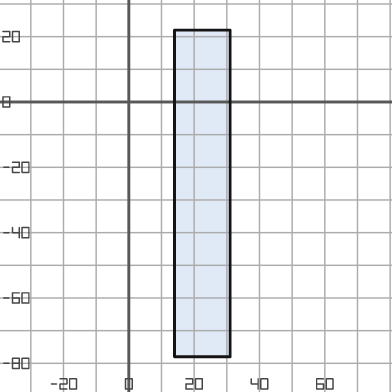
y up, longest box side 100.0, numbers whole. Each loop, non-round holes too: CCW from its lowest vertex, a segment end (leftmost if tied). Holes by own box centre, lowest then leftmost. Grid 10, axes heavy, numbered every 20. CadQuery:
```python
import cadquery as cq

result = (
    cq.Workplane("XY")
    .moveTo(14.0, -78.0)
    .lineTo(31.0, -78.0)
    .lineTo(31.0, 22.0)
    .lineTo(14.0, 22.0)
    .close()
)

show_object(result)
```